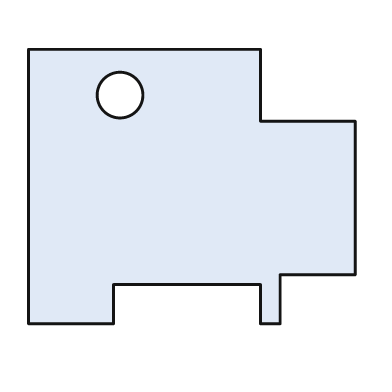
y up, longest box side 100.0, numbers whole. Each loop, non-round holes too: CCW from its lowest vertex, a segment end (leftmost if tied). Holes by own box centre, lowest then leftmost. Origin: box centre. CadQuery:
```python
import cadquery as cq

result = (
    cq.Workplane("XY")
    .moveTo(-50.0, -42.0)
    .lineTo(-24.0, -42.0)
    .lineTo(-24.0, -30.0)
    .lineTo(21.0, -30.0)
    .lineTo(21.0, -42.0)
    .lineTo(27.0, -42.0)
    .lineTo(27.0, -27.0)
    .lineTo(50.0, -27.0)
    .lineTo(50.0, 20.0)
    .lineTo(21.0, 20.0)
    .lineTo(21.0, 42.0)
    .lineTo(-50.0, 42.0)
    .close()
    .moveTo(-22.0, 28.0)
    .circle(7.0)
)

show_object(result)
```